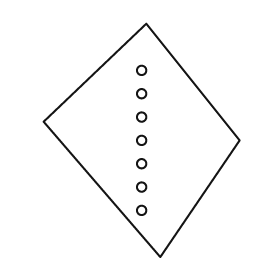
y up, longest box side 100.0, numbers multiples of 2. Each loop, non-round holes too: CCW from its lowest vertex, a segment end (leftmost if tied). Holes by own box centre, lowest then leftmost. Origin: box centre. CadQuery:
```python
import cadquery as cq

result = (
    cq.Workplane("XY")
    .moveTo(8.0, -50.0)
    .lineTo(42.0, 0.0)
    .lineTo(2.0, 50.0)
    .lineTo(-42.0, 8.0)
    .close()
    .moveTo(0.0, -30.0)
    .circle(2.0)
    .moveTo(0.0, -20.0)
    .circle(2.0)
    .moveTo(0.0, -10.0)
    .circle(2.0)
    .moveTo(0.0, 0.0)
    .circle(2.0)
    .moveTo(0.0, 10.0)
    .circle(2.0)
    .moveTo(0.0, 20.0)
    .circle(2.0)
    .moveTo(0.0, 30.0)
    .circle(2.0)
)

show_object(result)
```